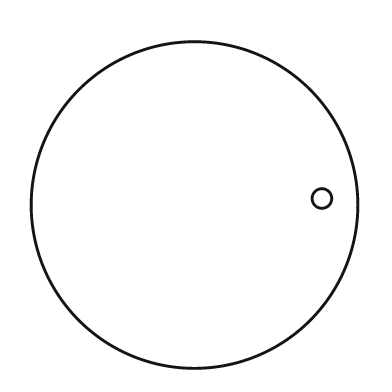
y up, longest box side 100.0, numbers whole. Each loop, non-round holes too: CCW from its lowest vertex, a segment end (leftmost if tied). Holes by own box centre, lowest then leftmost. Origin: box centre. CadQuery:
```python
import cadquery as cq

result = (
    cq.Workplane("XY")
    .moveTo(0.0, 0.0)
    .circle(50.0)
    .moveTo(39.0, 2.0)
    .circle(3.0)
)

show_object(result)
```